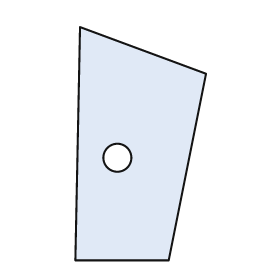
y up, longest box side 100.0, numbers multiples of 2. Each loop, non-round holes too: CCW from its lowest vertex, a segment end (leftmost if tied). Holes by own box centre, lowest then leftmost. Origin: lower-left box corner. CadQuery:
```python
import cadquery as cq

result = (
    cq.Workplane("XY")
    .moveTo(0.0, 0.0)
    .lineTo(40.0, 0.0)
    .lineTo(56.0, 80.0)
    .lineTo(2.0, 100.0)
    .close()
    .moveTo(18.0, 44.0)
    .circle(6.0)
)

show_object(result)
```